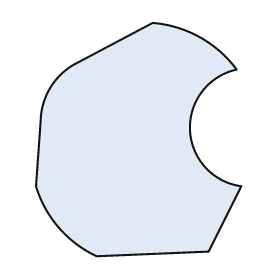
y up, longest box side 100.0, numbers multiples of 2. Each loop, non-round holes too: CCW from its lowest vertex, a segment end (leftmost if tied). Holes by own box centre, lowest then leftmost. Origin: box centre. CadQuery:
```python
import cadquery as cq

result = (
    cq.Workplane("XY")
    .moveTo(-18.0, -50.0)
    .lineTo(30.0, -48.0)
    .lineTo(44.0, -20.0)
    .threePointArc((22.0, 4.0), (42.0, 30.0))
    .threePointArc((26.0, 44.0), (6.0, 50.0))
    .lineTo(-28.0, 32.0)
    .threePointArc((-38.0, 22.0), (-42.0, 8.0))
    .lineTo(-44.0, -20.0)
    .threePointArc((-34.0, -38.0), (-18.0, -50.0))
    .close()
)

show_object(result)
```